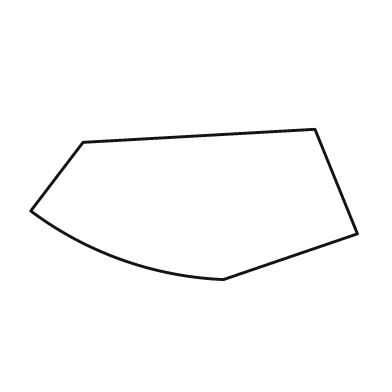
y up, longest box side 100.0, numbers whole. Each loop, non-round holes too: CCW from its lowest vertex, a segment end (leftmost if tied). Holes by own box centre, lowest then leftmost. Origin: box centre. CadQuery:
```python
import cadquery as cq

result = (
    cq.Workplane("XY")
    .moveTo(9.0, -23.0)
    .lineTo(50.0, -9.0)
    .lineTo(37.0, 23.0)
    .lineTo(-34.0, 19.0)
    .lineTo(-50.0, -2.0)
    .threePointArc((-22.0, -17.0), (9.0, -23.0))
    .close()
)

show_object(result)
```